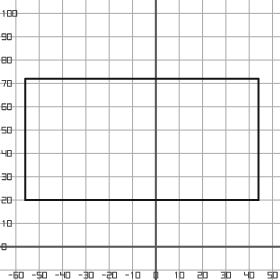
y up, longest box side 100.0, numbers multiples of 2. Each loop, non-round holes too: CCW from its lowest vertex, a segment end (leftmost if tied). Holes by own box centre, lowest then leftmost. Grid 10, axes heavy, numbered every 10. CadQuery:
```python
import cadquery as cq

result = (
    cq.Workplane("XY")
    .moveTo(-56.0, 20.0)
    .lineTo(44.0, 20.0)
    .lineTo(44.0, 72.0)
    .lineTo(-56.0, 72.0)
    .close()
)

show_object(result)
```